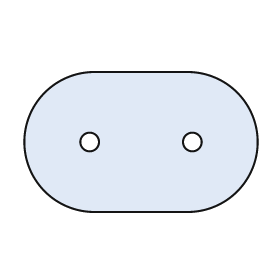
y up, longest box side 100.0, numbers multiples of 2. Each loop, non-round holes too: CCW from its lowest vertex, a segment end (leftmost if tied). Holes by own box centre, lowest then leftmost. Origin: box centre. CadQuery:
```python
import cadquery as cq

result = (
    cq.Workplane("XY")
    .moveTo(-20.0, -30.0)
    .lineTo(20.0, -30.0)
    .threePointArc((50.0, 0.0), (20.0, 30.0))
    .lineTo(-20.0, 30.0)
    .threePointArc((-50.0, 0.0), (-20.0, -30.0))
    .close()
    .moveTo(-22.0, 0.0)
    .circle(4.0)
    .moveTo(22.0, 0.0)
    .circle(4.0)
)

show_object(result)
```